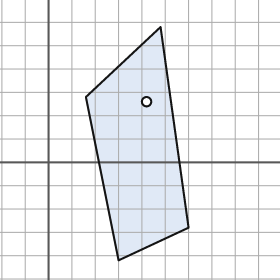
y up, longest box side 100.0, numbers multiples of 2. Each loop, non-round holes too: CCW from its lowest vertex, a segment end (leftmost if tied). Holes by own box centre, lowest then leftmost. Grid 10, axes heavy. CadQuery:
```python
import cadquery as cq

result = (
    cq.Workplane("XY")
    .moveTo(30.0, -42.0)
    .lineTo(60.0, -28.0)
    .lineTo(48.0, 58.0)
    .lineTo(16.0, 28.0)
    .close()
    .moveTo(42.0, 26.0)
    .circle(2.0)
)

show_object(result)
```